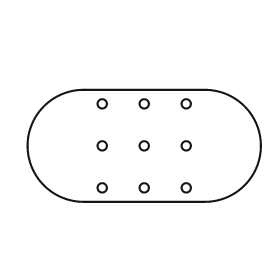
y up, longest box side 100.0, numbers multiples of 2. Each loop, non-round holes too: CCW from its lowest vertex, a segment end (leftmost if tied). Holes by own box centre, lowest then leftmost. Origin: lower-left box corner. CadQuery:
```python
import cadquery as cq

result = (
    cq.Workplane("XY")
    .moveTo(24.0, 0.0)
    .lineTo(76.0, 0.0)
    .threePointArc((100.0, 24.0), (76.0, 48.0))
    .lineTo(24.0, 48.0)
    .threePointArc((0.0, 24.0), (24.0, 0.0))
    .close()
    .moveTo(32.0, 6.0)
    .circle(2.0)
    .moveTo(50.0, 6.0)
    .circle(2.0)
    .moveTo(68.0, 6.0)
    .circle(2.0)
    .moveTo(32.0, 24.0)
    .circle(2.0)
    .moveTo(50.0, 24.0)
    .circle(2.0)
    .moveTo(68.0, 24.0)
    .circle(2.0)
    .moveTo(32.0, 42.0)
    .circle(2.0)
    .moveTo(50.0, 42.0)
    .circle(2.0)
    .moveTo(68.0, 42.0)
    .circle(2.0)
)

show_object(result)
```